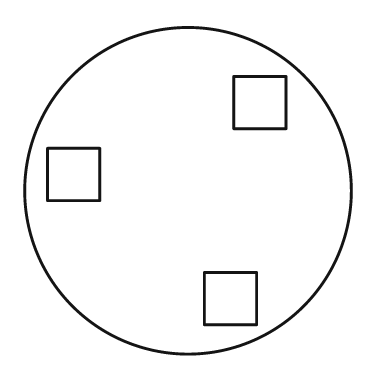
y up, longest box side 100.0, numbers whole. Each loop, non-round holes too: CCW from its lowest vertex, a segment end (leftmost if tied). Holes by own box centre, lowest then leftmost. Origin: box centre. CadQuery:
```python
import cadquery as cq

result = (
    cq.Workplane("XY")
    .moveTo(0.0, 0.0)
    .circle(50.0)
    .moveTo(5.0, -41.0)
    .lineTo(21.0, -41.0)
    .lineTo(21.0, -25.0)
    .lineTo(5.0, -25.0)
    .close()
    .moveTo(-43.0, -3.0)
    .lineTo(-27.0, -3.0)
    .lineTo(-27.0, 13.0)
    .lineTo(-43.0, 13.0)
    .close()
    .moveTo(14.0, 19.0)
    .lineTo(30.0, 19.0)
    .lineTo(30.0, 35.0)
    .lineTo(14.0, 35.0)
    .close()
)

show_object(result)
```